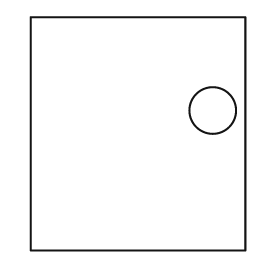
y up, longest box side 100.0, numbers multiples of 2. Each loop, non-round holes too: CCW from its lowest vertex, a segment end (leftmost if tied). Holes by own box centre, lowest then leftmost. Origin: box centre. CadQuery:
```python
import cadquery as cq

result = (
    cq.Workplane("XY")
    .moveTo(-46.0, -50.0)
    .lineTo(46.0, -50.0)
    .lineTo(46.0, 50.0)
    .lineTo(-46.0, 50.0)
    .close()
    .moveTo(32.0, 10.0)
    .circle(10.0)
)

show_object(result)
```